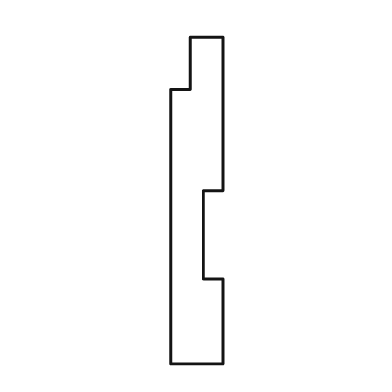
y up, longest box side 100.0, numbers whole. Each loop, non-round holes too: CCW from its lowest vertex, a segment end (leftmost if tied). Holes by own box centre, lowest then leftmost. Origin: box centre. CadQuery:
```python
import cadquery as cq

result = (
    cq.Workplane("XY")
    .moveTo(-8.0, -50.0)
    .lineTo(8.0, -50.0)
    .lineTo(8.0, -24.0)
    .lineTo(2.0, -24.0)
    .lineTo(2.0, 3.0)
    .lineTo(8.0, 3.0)
    .lineTo(8.0, 50.0)
    .lineTo(-2.0, 50.0)
    .lineTo(-2.0, 34.0)
    .lineTo(-8.0, 34.0)
    .close()
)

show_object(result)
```